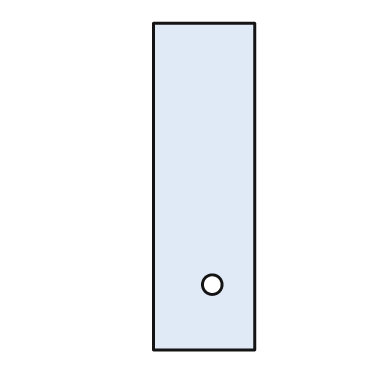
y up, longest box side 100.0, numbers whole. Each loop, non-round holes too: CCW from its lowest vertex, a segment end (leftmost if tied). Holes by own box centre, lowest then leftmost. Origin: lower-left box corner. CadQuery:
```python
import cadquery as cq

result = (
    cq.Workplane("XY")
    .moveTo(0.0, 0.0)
    .lineTo(31.0, 0.0)
    .lineTo(31.0, 100.0)
    .lineTo(0.0, 100.0)
    .close()
    .moveTo(18.0, 20.0)
    .circle(3.0)
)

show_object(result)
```